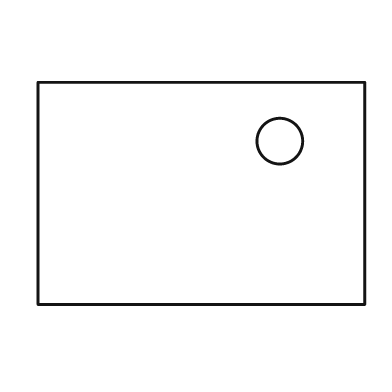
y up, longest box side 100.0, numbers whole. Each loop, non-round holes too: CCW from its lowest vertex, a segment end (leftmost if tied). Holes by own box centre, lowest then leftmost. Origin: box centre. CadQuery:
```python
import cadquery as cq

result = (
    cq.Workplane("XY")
    .moveTo(-50.0, -34.0)
    .lineTo(50.0, -34.0)
    .lineTo(50.0, 34.0)
    .lineTo(-50.0, 34.0)
    .close()
    .moveTo(24.0, 16.0)
    .circle(7.0)
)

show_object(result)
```